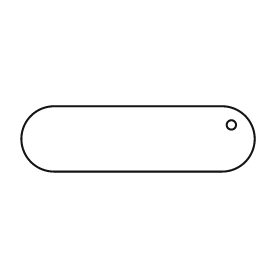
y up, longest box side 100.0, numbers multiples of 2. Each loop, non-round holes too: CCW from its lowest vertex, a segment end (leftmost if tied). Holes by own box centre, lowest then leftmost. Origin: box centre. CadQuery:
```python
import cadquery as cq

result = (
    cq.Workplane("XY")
    .moveTo(-36.0, -14.0)
    .lineTo(36.0, -14.0)
    .threePointArc((50.0, 0.0), (36.0, 14.0))
    .lineTo(-36.0, 14.0)
    .threePointArc((-50.0, 0.0), (-36.0, -14.0))
    .close()
    .moveTo(40.0, 6.0)
    .circle(2.0)
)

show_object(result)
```